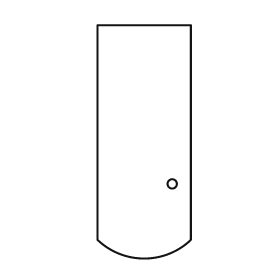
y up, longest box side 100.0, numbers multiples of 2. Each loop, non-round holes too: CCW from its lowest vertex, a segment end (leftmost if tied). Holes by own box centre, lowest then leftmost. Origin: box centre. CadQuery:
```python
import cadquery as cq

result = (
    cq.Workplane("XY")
    .moveTo(-20.0, -42.0)
    .threePointArc((0.0, -50.0), (20.0, -42.0))
    .lineTo(20.0, 50.0)
    .lineTo(-20.0, 50.0)
    .close()
    .moveTo(12.0, -18.0)
    .circle(2.0)
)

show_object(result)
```